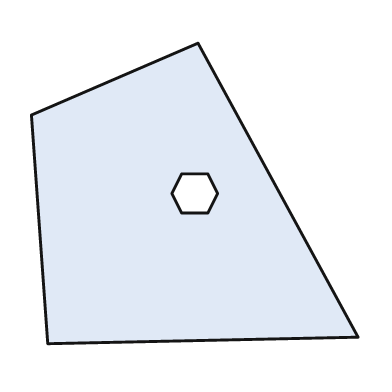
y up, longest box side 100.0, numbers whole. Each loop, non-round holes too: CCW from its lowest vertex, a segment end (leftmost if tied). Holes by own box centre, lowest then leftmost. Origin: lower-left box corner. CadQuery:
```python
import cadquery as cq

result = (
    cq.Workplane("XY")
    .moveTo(5.0, 0.0)
    .lineTo(100.0, 2.0)
    .lineTo(51.0, 92.0)
    .lineTo(0.0, 70.0)
    .close()
    .moveTo(46.0, 40.0)
    .lineTo(54.0, 40.0)
    .lineTo(57.0, 46.0)
    .lineTo(54.0, 52.0)
    .lineTo(46.0, 52.0)
    .lineTo(43.0, 46.0)
    .close()
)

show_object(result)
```